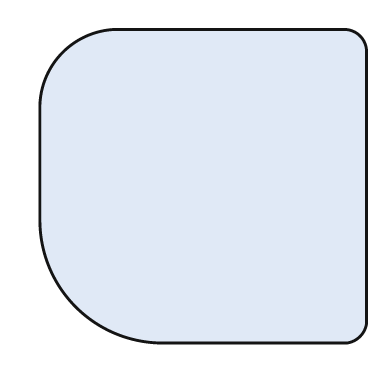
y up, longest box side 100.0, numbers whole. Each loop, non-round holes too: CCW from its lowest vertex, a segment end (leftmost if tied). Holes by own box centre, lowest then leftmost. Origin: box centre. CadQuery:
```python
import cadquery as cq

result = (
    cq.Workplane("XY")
    .moveTo(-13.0, -48.0)
    .lineTo(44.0, -48.0)
    .threePointArc((48.0, -46.0), (50.0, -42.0))
    .lineTo(50.0, 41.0)
    .threePointArc((48.0, 46.0), (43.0, 48.0))
    .lineTo(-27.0, 48.0)
    .threePointArc((-43.0, 41.0), (-50.0, 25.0))
    .lineTo(-50.0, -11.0)
    .threePointArc((-39.0, -37.0), (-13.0, -48.0))
    .close()
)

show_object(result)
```